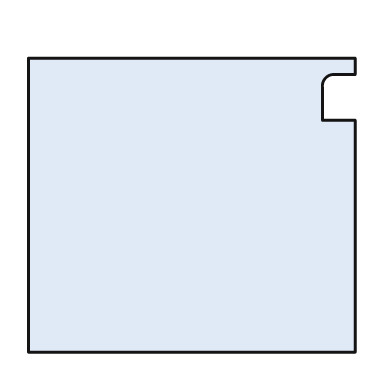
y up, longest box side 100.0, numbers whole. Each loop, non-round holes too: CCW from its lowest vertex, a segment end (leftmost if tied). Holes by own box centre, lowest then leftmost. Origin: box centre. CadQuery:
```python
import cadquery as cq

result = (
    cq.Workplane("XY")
    .moveTo(-50.0, -45.0)
    .lineTo(50.0, -45.0)
    .lineTo(50.0, 26.0)
    .lineTo(40.0, 26.0)
    .lineTo(40.0, 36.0)
    .threePointArc((41.0, 39.0), (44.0, 40.0))
    .lineTo(50.0, 40.0)
    .lineTo(50.0, 45.0)
    .lineTo(-50.0, 45.0)
    .close()
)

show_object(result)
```